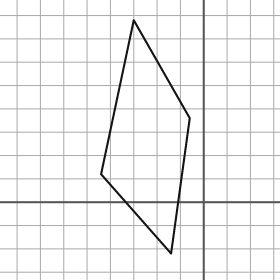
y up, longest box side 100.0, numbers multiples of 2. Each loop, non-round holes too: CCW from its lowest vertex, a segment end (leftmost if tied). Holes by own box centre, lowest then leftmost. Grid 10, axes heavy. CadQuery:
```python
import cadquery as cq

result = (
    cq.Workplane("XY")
    .moveTo(-14.0, -22.0)
    .lineTo(-6.0, 36.0)
    .lineTo(-30.0, 78.0)
    .lineTo(-44.0, 12.0)
    .close()
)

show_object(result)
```